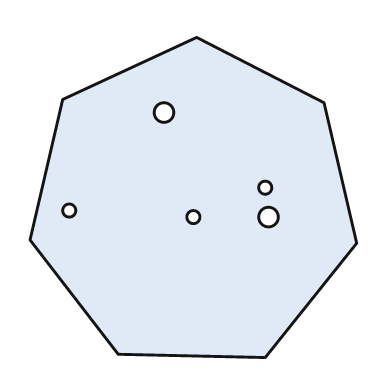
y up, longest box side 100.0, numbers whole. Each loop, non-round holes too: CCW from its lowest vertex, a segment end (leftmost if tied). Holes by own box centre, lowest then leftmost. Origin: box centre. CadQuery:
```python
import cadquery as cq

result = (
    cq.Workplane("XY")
    .moveTo(22.0, -49.0)
    .lineTo(50.0, -14.0)
    .lineTo(40.0, 29.0)
    .lineTo(1.0, 49.0)
    .lineTo(-40.0, 30.0)
    .lineTo(-50.0, -13.0)
    .lineTo(-23.0, -48.0)
    .close()
    .moveTo(0.0, -6.0)
    .circle(2.0)
    .moveTo(23.0, -6.0)
    .circle(3.0)
    .moveTo(-38.0, -4.0)
    .circle(2.0)
    .moveTo(22.0, 3.0)
    .circle(2.0)
    .moveTo(-9.0, 26.0)
    .circle(3.0)
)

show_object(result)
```